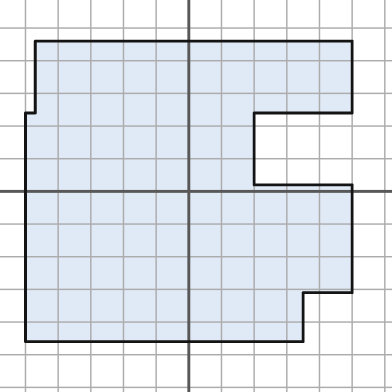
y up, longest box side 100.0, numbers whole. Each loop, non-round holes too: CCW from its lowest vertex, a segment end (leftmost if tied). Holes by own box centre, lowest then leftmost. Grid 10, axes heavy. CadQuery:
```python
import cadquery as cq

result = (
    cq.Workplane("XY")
    .moveTo(-50.0, -46.0)
    .lineTo(35.0, -46.0)
    .lineTo(35.0, -31.0)
    .lineTo(50.0, -31.0)
    .lineTo(50.0, 2.0)
    .lineTo(20.0, 2.0)
    .lineTo(20.0, 24.0)
    .lineTo(50.0, 24.0)
    .lineTo(50.0, 46.0)
    .lineTo(-47.0, 46.0)
    .lineTo(-47.0, 24.0)
    .lineTo(-50.0, 24.0)
    .close()
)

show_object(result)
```